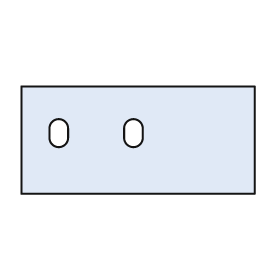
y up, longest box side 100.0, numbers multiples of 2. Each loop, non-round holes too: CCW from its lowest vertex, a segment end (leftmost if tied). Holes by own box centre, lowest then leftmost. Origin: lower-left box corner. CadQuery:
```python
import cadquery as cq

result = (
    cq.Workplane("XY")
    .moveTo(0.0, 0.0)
    .lineTo(100.0, 0.0)
    .lineTo(100.0, 46.0)
    .lineTo(0.0, 46.0)
    .close()
    .moveTo(12.0, 24.0)
    .threePointArc((16.0, 20.0), (20.0, 24.0))
    .lineTo(20.0, 28.0)
    .threePointArc((16.0, 32.0), (12.0, 28.0))
    .close()
    .moveTo(44.0, 24.0)
    .threePointArc((48.0, 20.0), (52.0, 24.0))
    .lineTo(52.0, 28.0)
    .threePointArc((48.0, 32.0), (44.0, 28.0))
    .close()
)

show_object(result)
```